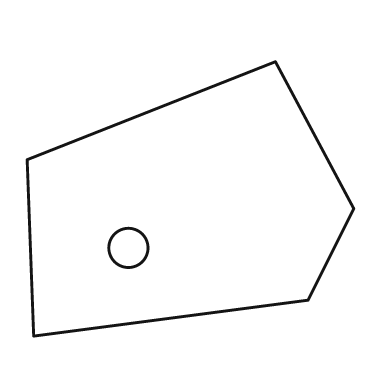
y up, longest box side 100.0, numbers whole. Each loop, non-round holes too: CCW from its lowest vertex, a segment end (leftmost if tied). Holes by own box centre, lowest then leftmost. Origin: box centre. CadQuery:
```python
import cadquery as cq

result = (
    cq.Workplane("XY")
    .moveTo(-48.0, -42.0)
    .lineTo(36.0, -31.0)
    .lineTo(50.0, -3.0)
    .lineTo(26.0, 42.0)
    .lineTo(-50.0, 12.0)
    .close()
    .moveTo(-19.0, -15.0)
    .circle(6.0)
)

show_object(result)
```